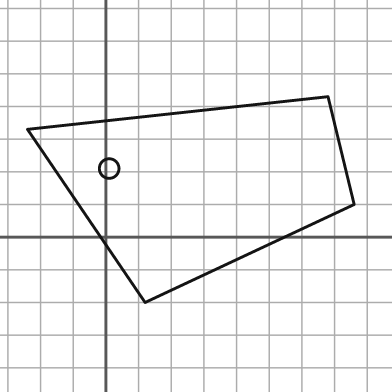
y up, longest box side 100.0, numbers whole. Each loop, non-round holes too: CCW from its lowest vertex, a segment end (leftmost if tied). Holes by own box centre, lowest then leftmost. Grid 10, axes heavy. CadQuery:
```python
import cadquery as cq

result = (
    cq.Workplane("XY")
    .moveTo(12.0, -20.0)
    .lineTo(76.0, 10.0)
    .lineTo(68.0, 43.0)
    .lineTo(-24.0, 33.0)
    .close()
    .moveTo(1.0, 21.0)
    .circle(3.0)
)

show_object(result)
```